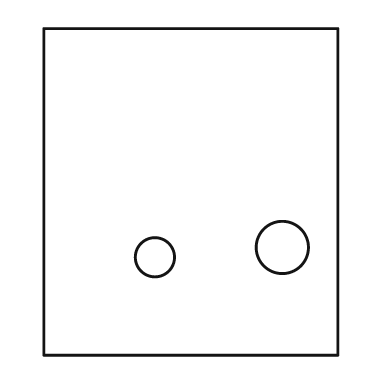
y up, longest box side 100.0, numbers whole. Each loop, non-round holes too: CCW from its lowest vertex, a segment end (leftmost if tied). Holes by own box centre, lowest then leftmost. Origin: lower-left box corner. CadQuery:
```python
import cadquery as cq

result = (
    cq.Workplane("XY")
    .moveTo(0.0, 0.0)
    .lineTo(90.0, 0.0)
    .lineTo(90.0, 100.0)
    .lineTo(0.0, 100.0)
    .close()
    .moveTo(34.0, 30.0)
    .circle(6.0)
    .moveTo(73.0, 33.0)
    .circle(8.0)
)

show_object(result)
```